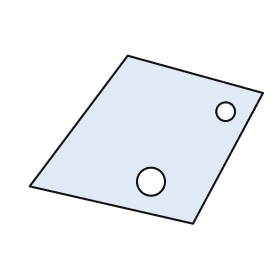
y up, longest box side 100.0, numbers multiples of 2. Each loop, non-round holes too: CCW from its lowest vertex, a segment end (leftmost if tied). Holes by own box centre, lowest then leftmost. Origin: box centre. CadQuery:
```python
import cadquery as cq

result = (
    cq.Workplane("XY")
    .moveTo(20.0, -36.0)
    .lineTo(50.0, 20.0)
    .lineTo(-8.0, 36.0)
    .lineTo(-50.0, -20.0)
    .close()
    .moveTo(2.0, -18.0)
    .circle(6.0)
    .moveTo(34.0, 12.0)
    .circle(4.0)
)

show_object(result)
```